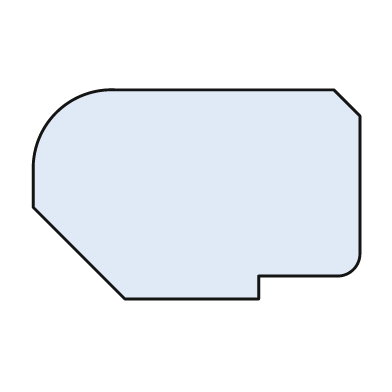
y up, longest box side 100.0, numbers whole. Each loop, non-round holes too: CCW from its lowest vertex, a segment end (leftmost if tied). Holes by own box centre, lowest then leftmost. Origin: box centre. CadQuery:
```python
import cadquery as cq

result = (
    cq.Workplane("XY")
    .moveTo(-22.0, -32.0)
    .lineTo(19.0, -32.0)
    .lineTo(19.0, -25.0)
    .lineTo(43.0, -25.0)
    .threePointArc((48.0, -23.0), (50.0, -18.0))
    .lineTo(50.0, 24.0)
    .lineTo(42.0, 32.0)
    .lineTo(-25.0, 32.0)
    .threePointArc((-43.0, 25.0), (-50.0, 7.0))
    .lineTo(-50.0, -4.0)
    .close()
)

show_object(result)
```